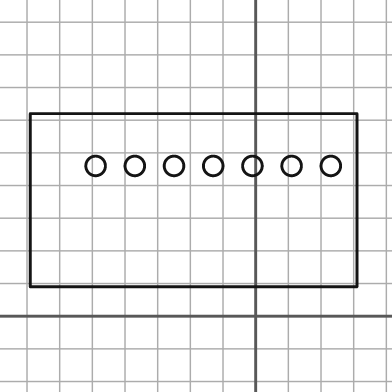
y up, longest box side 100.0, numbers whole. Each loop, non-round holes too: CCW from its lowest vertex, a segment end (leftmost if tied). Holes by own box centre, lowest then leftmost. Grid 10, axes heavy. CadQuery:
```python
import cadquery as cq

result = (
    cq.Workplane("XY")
    .moveTo(-69.0, 9.0)
    .lineTo(31.0, 9.0)
    .lineTo(31.0, 62.0)
    .lineTo(-69.0, 62.0)
    .close()
    .moveTo(-49.0, 46.0)
    .circle(3.0)
    .moveTo(-37.0, 46.0)
    .circle(3.0)
    .moveTo(-25.0, 46.0)
    .circle(3.0)
    .moveTo(-13.0, 46.0)
    .circle(3.0)
    .moveTo(-1.0, 46.0)
    .circle(3.0)
    .moveTo(11.0, 46.0)
    .circle(3.0)
    .moveTo(23.0, 46.0)
    .circle(3.0)
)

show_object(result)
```